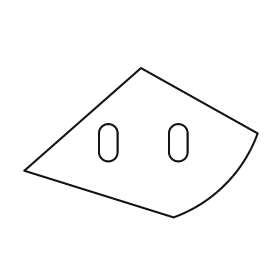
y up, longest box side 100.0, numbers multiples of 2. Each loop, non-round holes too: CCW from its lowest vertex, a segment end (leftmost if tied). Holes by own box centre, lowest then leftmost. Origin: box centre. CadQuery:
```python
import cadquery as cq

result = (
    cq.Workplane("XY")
    .moveTo(14.0, -32.0)
    .threePointArc((36.0, -18.0), (50.0, 4.0))
    .lineTo(0.0, 32.0)
    .lineTo(-50.0, -12.0)
    .close()
    .moveTo(-18.0, -4.0)
    .threePointArc((-14.0, -8.0), (-10.0, -4.0))
    .lineTo(-10.0, 4.0)
    .threePointArc((-14.0, 8.0), (-18.0, 4.0))
    .close()
    .moveTo(12.0, -4.0)
    .threePointArc((16.0, -8.0), (20.0, -4.0))
    .lineTo(20.0, 4.0)
    .threePointArc((16.0, 8.0), (12.0, 4.0))
    .close()
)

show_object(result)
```